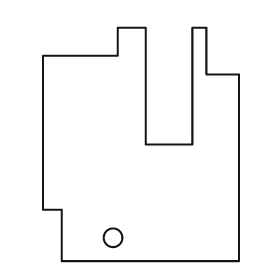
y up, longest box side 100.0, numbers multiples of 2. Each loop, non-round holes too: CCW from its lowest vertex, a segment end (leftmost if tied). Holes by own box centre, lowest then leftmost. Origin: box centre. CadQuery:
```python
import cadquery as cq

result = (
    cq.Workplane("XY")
    .moveTo(-34.0, -50.0)
    .lineTo(42.0, -50.0)
    .lineTo(42.0, 30.0)
    .lineTo(28.0, 30.0)
    .lineTo(28.0, 50.0)
    .lineTo(22.0, 50.0)
    .lineTo(22.0, 0.0)
    .lineTo(2.0, 0.0)
    .lineTo(2.0, 50.0)
    .lineTo(-10.0, 50.0)
    .lineTo(-10.0, 38.0)
    .lineTo(-42.0, 38.0)
    .lineTo(-42.0, -28.0)
    .lineTo(-34.0, -28.0)
    .close()
    .moveTo(-12.0, -40.0)
    .circle(4.0)
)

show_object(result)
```